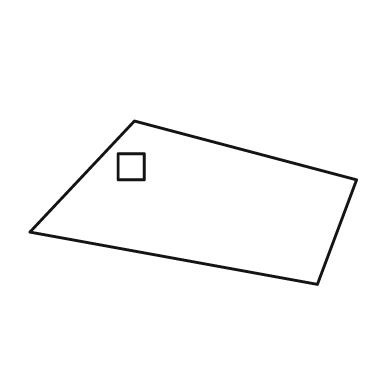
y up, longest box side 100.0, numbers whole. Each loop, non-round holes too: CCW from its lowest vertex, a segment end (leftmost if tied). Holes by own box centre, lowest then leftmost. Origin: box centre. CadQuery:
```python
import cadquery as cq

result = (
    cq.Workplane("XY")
    .moveTo(38.0, -25.0)
    .lineTo(50.0, 7.0)
    .lineTo(-18.0, 25.0)
    .lineTo(-50.0, -9.0)
    .close()
    .moveTo(-23.0, 7.0)
    .lineTo(-15.0, 7.0)
    .lineTo(-15.0, 15.0)
    .lineTo(-23.0, 15.0)
    .close()
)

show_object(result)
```